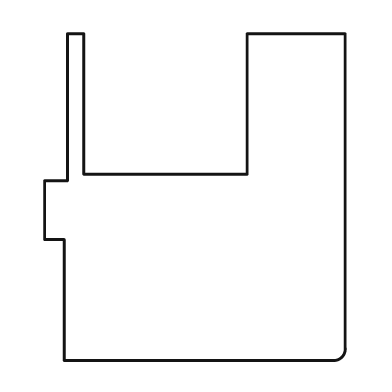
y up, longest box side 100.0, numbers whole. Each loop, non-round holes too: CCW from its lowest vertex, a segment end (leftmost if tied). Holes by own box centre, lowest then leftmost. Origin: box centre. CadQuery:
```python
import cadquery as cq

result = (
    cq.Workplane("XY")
    .moveTo(-40.0, -50.0)
    .lineTo(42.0, -50.0)
    .threePointArc((45.0, -49.0), (46.0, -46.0))
    .lineTo(46.0, 50.0)
    .lineTo(16.0, 50.0)
    .lineTo(16.0, 7.0)
    .lineTo(-34.0, 7.0)
    .lineTo(-34.0, 50.0)
    .lineTo(-39.0, 50.0)
    .lineTo(-39.0, 5.0)
    .lineTo(-46.0, 5.0)
    .lineTo(-46.0, -13.0)
    .lineTo(-40.0, -13.0)
    .close()
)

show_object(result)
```